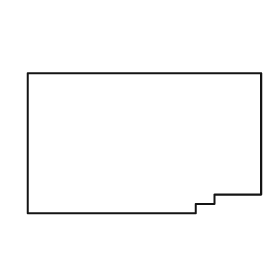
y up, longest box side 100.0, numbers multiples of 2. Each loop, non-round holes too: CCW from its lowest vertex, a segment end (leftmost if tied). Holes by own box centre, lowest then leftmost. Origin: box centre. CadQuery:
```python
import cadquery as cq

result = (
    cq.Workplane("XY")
    .moveTo(-50.0, -30.0)
    .lineTo(22.0, -30.0)
    .lineTo(22.0, -26.0)
    .lineTo(30.0, -26.0)
    .lineTo(30.0, -22.0)
    .lineTo(50.0, -22.0)
    .lineTo(50.0, 30.0)
    .lineTo(-50.0, 30.0)
    .close()
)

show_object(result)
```